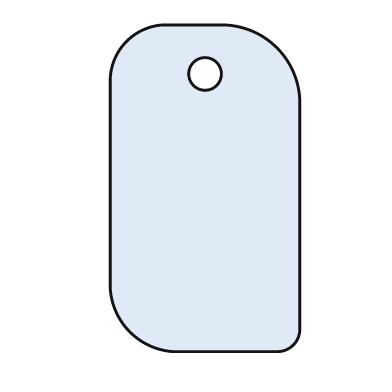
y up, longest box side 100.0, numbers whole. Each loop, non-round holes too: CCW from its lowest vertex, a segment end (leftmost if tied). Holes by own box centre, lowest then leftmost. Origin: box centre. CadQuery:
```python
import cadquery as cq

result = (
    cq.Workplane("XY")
    .moveTo(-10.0, -50.0)
    .lineTo(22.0, -50.0)
    .threePointArc((27.0, -48.0), (29.0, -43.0))
    .lineTo(29.0, 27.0)
    .threePointArc((22.0, 43.0), (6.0, 50.0))
    .lineTo(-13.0, 50.0)
    .threePointArc((-24.0, 45.0), (-29.0, 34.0))
    .lineTo(-29.0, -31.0)
    .threePointArc((-23.0, -44.0), (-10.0, -50.0))
    .close()
    .moveTo(0.0, 35.0)
    .circle(5.0)
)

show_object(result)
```